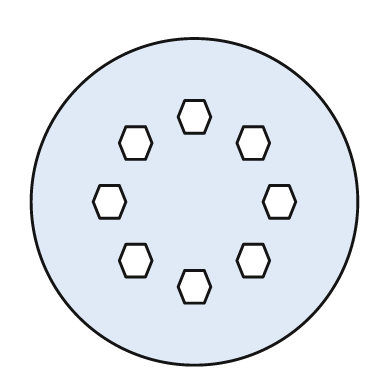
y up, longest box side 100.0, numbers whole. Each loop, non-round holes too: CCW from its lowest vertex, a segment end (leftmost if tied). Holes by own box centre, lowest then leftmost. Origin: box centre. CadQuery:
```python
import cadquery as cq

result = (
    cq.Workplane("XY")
    .moveTo(0.0, 0.0)
    .circle(50.0)
    .moveTo(-3.0, -31.0)
    .lineTo(3.0, -31.0)
    .lineTo(5.0, -26.0)
    .lineTo(3.0, -21.0)
    .lineTo(-3.0, -21.0)
    .lineTo(-5.0, -26.0)
    .close()
    .moveTo(-21.0, -23.0)
    .lineTo(-15.0, -23.0)
    .lineTo(-13.0, -18.0)
    .lineTo(-15.0, -13.0)
    .lineTo(-21.0, -13.0)
    .lineTo(-23.0, -18.0)
    .close()
    .moveTo(15.0, -23.0)
    .lineTo(21.0, -23.0)
    .lineTo(23.0, -18.0)
    .lineTo(21.0, -13.0)
    .lineTo(15.0, -13.0)
    .lineTo(13.0, -18.0)
    .close()
    .moveTo(-29.0, -5.0)
    .lineTo(-23.0, -5.0)
    .lineTo(-21.0, 0.0)
    .lineTo(-23.0, 5.0)
    .lineTo(-29.0, 5.0)
    .lineTo(-31.0, 0.0)
    .close()
    .moveTo(23.0, -5.0)
    .lineTo(29.0, -5.0)
    .lineTo(31.0, 0.0)
    .lineTo(29.0, 5.0)
    .lineTo(23.0, 5.0)
    .lineTo(21.0, 0.0)
    .close()
    .moveTo(-21.0, 13.0)
    .lineTo(-15.0, 13.0)
    .lineTo(-13.0, 18.0)
    .lineTo(-15.0, 23.0)
    .lineTo(-21.0, 23.0)
    .lineTo(-23.0, 18.0)
    .close()
    .moveTo(15.0, 13.0)
    .lineTo(21.0, 13.0)
    .lineTo(23.0, 18.0)
    .lineTo(21.0, 23.0)
    .lineTo(15.0, 23.0)
    .lineTo(13.0, 18.0)
    .close()
    .moveTo(-3.0, 21.0)
    .lineTo(3.0, 21.0)
    .lineTo(5.0, 26.0)
    .lineTo(3.0, 31.0)
    .lineTo(-3.0, 31.0)
    .lineTo(-5.0, 26.0)
    .close()
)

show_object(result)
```